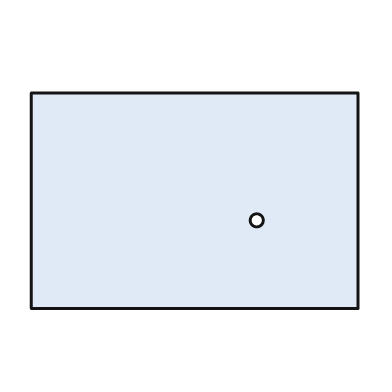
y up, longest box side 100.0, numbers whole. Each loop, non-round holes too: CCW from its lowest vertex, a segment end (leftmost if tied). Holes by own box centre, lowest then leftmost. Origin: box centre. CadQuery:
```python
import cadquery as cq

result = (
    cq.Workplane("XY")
    .moveTo(-50.0, -33.0)
    .lineTo(50.0, -33.0)
    .lineTo(50.0, 33.0)
    .lineTo(-50.0, 33.0)
    .close()
    .moveTo(19.0, -6.0)
    .circle(2.0)
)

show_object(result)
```